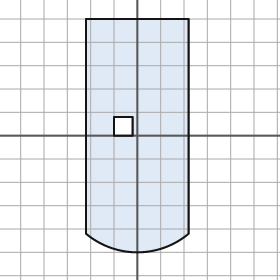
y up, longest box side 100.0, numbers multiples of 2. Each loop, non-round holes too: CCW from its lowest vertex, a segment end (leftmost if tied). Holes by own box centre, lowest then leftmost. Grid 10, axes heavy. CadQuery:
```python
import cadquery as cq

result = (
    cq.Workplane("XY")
    .moveTo(-22.0, -42.0)
    .threePointArc((0.0, -50.0), (22.0, -42.0))
    .lineTo(22.0, 50.0)
    .lineTo(-22.0, 50.0)
    .close()
    .moveTo(-10.0, 0.0)
    .lineTo(-2.0, 0.0)
    .lineTo(-2.0, 8.0)
    .lineTo(-10.0, 8.0)
    .close()
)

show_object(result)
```